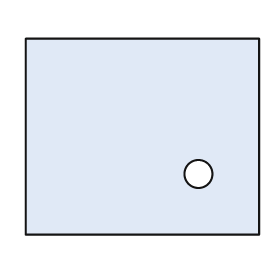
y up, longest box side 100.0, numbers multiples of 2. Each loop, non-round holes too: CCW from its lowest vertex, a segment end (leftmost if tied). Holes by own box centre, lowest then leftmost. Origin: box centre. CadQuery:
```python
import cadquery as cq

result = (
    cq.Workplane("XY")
    .moveTo(-50.0, -42.0)
    .lineTo(50.0, -42.0)
    .lineTo(50.0, 42.0)
    .lineTo(-50.0, 42.0)
    .close()
    .moveTo(24.0, -16.0)
    .circle(6.0)
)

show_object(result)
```